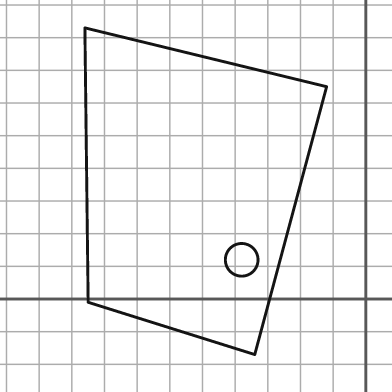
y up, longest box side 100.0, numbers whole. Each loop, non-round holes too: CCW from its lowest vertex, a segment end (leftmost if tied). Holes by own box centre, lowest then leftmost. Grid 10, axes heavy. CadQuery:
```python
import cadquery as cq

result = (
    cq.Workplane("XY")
    .moveTo(-34.0, -17.0)
    .lineTo(-12.0, 65.0)
    .lineTo(-86.0, 83.0)
    .lineTo(-85.0, -1.0)
    .close()
    .moveTo(-38.0, 12.0)
    .circle(5.0)
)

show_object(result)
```